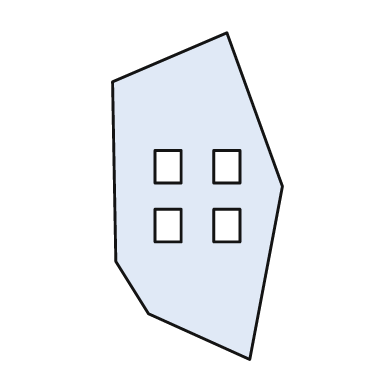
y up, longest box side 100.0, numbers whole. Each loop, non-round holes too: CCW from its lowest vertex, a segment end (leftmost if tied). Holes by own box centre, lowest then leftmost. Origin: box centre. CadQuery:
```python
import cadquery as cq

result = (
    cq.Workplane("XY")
    .moveTo(16.0, -50.0)
    .lineTo(26.0, 3.0)
    .lineTo(9.0, 50.0)
    .lineTo(-26.0, 35.0)
    .lineTo(-25.0, -20.0)
    .lineTo(-15.0, -36.0)
    .close()
    .moveTo(-13.0, -14.0)
    .lineTo(-5.0, -14.0)
    .lineTo(-5.0, -4.0)
    .lineTo(-13.0, -4.0)
    .close()
    .moveTo(5.0, -14.0)
    .lineTo(13.0, -14.0)
    .lineTo(13.0, -4.0)
    .lineTo(5.0, -4.0)
    .close()
    .moveTo(-13.0, 4.0)
    .lineTo(-5.0, 4.0)
    .lineTo(-5.0, 14.0)
    .lineTo(-13.0, 14.0)
    .close()
    .moveTo(5.0, 4.0)
    .lineTo(13.0, 4.0)
    .lineTo(13.0, 14.0)
    .lineTo(5.0, 14.0)
    .close()
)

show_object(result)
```